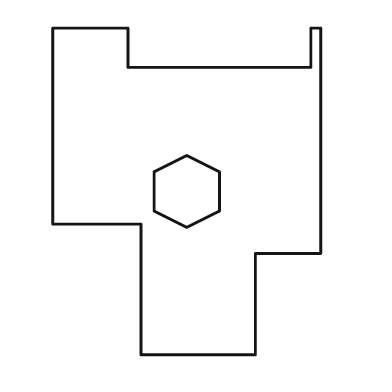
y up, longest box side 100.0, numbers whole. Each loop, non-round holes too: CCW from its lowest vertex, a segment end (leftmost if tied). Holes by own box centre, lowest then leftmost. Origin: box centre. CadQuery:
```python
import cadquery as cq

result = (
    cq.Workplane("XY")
    .moveTo(-14.0, -50.0)
    .lineTo(21.0, -50.0)
    .lineTo(21.0, -19.0)
    .lineTo(41.0, -19.0)
    .lineTo(41.0, 50.0)
    .lineTo(38.0, 50.0)
    .lineTo(38.0, 38.0)
    .lineTo(-18.0, 38.0)
    .lineTo(-18.0, 50.0)
    .lineTo(-41.0, 50.0)
    .lineTo(-41.0, -10.0)
    .lineTo(-14.0, -10.0)
    .close()
    .moveTo(0.0, -11.0)
    .lineTo(10.0, -6.0)
    .lineTo(10.0, 6.0)
    .lineTo(0.0, 11.0)
    .lineTo(-10.0, 6.0)
    .lineTo(-10.0, -6.0)
    .close()
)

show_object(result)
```